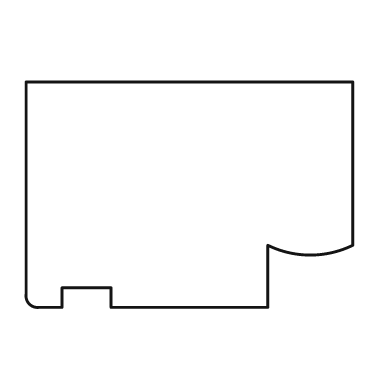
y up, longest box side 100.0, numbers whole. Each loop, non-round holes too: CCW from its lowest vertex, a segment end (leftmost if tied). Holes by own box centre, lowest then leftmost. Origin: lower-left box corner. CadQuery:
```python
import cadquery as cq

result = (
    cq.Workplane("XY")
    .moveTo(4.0, 0.0)
    .lineTo(11.0, 0.0)
    .lineTo(11.0, 6.0)
    .lineTo(26.0, 6.0)
    .lineTo(26.0, 0.0)
    .lineTo(74.0, 0.0)
    .lineTo(74.0, 19.0)
    .threePointArc((87.0, 16.0), (100.0, 19.0))
    .lineTo(100.0, 69.0)
    .lineTo(0.0, 69.0)
    .lineTo(0.0, 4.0)
    .threePointArc((1.0, 1.0), (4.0, 0.0))
    .close()
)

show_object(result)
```